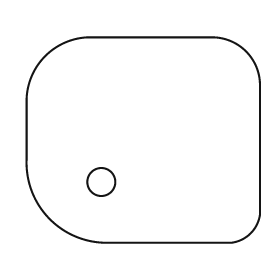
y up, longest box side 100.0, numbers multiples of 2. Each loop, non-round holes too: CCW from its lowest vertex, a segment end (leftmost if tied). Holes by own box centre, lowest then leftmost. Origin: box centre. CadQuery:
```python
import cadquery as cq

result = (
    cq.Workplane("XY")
    .moveTo(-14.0, -44.0)
    .lineTo(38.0, -44.0)
    .threePointArc((46.0, -40.0), (50.0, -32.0))
    .lineTo(50.0, 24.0)
    .threePointArc((44.0, 38.0), (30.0, 44.0))
    .lineTo(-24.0, 44.0)
    .threePointArc((-42.0, 36.0), (-50.0, 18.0))
    .lineTo(-50.0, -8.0)
    .threePointArc((-40.0, -34.0), (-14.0, -44.0))
    .close()
    .moveTo(-18.0, -18.0)
    .circle(6.0)
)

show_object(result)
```